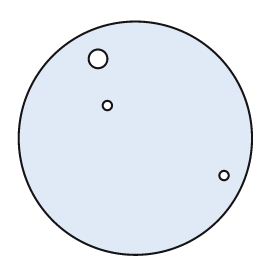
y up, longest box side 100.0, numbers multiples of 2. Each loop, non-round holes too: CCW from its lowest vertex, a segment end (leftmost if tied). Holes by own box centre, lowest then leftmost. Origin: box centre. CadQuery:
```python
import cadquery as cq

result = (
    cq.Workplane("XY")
    .moveTo(0.0, 0.0)
    .circle(50.0)
    .moveTo(38.0, -16.0)
    .circle(2.0)
    .moveTo(-12.0, 14.0)
    .circle(2.0)
    .moveTo(-16.0, 34.0)
    .circle(4.0)
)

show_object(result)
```